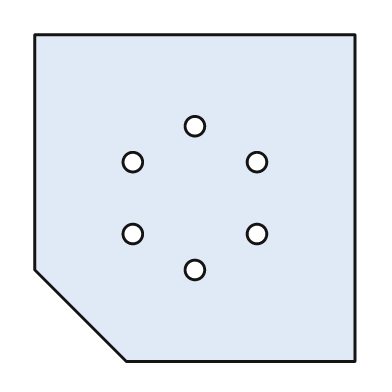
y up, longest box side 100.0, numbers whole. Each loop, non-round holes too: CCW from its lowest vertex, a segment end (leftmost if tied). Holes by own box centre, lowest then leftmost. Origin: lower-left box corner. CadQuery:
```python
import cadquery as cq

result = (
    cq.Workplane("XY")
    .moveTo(28.0, 0.0)
    .lineTo(98.0, 0.0)
    .lineTo(98.0, 100.0)
    .lineTo(0.0, 100.0)
    .lineTo(0.0, 28.0)
    .close()
    .moveTo(49.0, 28.0)
    .circle(3.0)
    .moveTo(30.0, 39.0)
    .circle(3.0)
    .moveTo(68.0, 39.0)
    .circle(3.0)
    .moveTo(30.0, 61.0)
    .circle(3.0)
    .moveTo(68.0, 61.0)
    .circle(3.0)
    .moveTo(49.0, 72.0)
    .circle(3.0)
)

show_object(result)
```